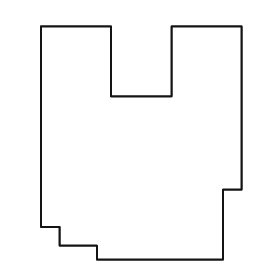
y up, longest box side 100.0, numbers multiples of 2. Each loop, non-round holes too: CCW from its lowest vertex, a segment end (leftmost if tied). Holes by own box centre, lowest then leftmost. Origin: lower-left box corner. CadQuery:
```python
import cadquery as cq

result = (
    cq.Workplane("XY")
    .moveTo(24.0, 0.0)
    .lineTo(78.0, 0.0)
    .lineTo(78.0, 30.0)
    .lineTo(86.0, 30.0)
    .lineTo(86.0, 100.0)
    .lineTo(56.0, 100.0)
    .lineTo(56.0, 70.0)
    .lineTo(30.0, 70.0)
    .lineTo(30.0, 100.0)
    .lineTo(0.0, 100.0)
    .lineTo(0.0, 14.0)
    .lineTo(8.0, 14.0)
    .lineTo(8.0, 6.0)
    .lineTo(24.0, 6.0)
    .close()
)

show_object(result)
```